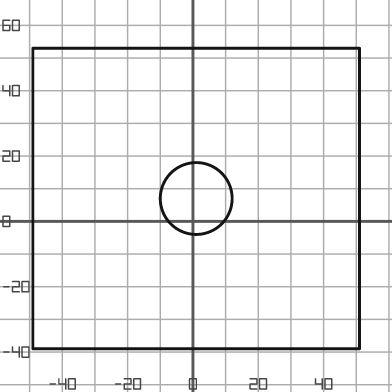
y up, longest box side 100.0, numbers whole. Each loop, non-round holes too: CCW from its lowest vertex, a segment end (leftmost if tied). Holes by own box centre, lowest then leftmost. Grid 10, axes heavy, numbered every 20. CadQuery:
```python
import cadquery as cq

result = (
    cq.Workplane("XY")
    .moveTo(-49.0, -39.0)
    .lineTo(51.0, -39.0)
    .lineTo(51.0, 53.0)
    .lineTo(-49.0, 53.0)
    .close()
    .moveTo(1.0, 7.0)
    .circle(11.0)
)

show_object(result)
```